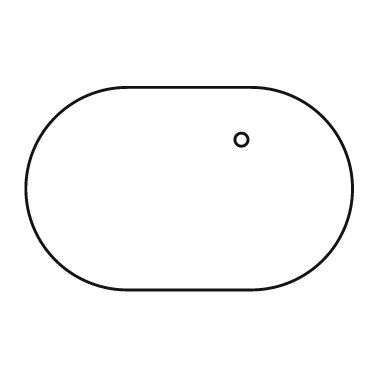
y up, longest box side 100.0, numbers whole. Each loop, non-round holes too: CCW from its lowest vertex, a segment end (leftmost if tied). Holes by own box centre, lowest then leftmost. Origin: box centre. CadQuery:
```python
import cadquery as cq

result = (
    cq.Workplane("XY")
    .moveTo(-19.0, -31.0)
    .lineTo(19.0, -31.0)
    .threePointArc((50.0, 0.0), (19.0, 31.0))
    .lineTo(-19.0, 31.0)
    .threePointArc((-50.0, 0.0), (-19.0, -31.0))
    .close()
    .moveTo(16.0, 15.0)
    .circle(2.0)
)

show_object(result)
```